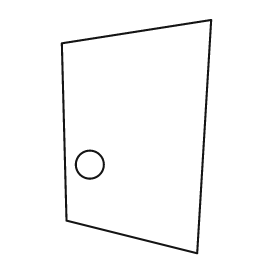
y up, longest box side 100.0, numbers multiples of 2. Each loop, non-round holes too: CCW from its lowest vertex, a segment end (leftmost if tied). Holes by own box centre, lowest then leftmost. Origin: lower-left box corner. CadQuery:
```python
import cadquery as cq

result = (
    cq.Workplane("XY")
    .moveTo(58.0, 0.0)
    .lineTo(64.0, 100.0)
    .lineTo(0.0, 90.0)
    .lineTo(2.0, 14.0)
    .close()
    .moveTo(12.0, 38.0)
    .circle(6.0)
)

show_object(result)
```